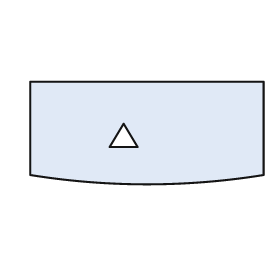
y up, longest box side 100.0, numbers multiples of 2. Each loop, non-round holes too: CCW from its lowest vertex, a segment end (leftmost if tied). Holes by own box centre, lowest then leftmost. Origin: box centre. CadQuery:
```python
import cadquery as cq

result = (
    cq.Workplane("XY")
    .moveTo(-50.0, -18.0)
    .threePointArc((0.0, -22.0), (50.0, -18.0))
    .lineTo(50.0, 22.0)
    .lineTo(-50.0, 22.0)
    .close()
    .moveTo(-16.0, -6.0)
    .lineTo(-4.0, -6.0)
    .lineTo(-10.0, 4.0)
    .close()
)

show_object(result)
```